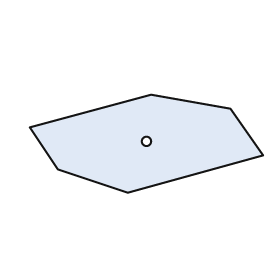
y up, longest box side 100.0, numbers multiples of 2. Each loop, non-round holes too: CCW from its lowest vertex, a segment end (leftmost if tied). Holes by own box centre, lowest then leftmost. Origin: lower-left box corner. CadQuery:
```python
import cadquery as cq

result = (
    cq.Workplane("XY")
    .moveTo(42.0, 0.0)
    .lineTo(100.0, 16.0)
    .lineTo(86.0, 36.0)
    .lineTo(52.0, 42.0)
    .lineTo(0.0, 28.0)
    .lineTo(12.0, 10.0)
    .close()
    .moveTo(50.0, 22.0)
    .circle(2.0)
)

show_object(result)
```